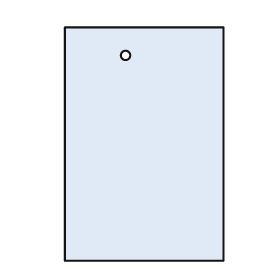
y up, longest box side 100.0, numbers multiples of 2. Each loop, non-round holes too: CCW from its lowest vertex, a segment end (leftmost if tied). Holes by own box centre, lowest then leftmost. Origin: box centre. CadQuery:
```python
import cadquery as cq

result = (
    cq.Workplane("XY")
    .moveTo(-34.0, -50.0)
    .lineTo(34.0, -50.0)
    .lineTo(34.0, 50.0)
    .lineTo(-34.0, 50.0)
    .close()
    .moveTo(-8.0, 38.0)
    .circle(2.0)
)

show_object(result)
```